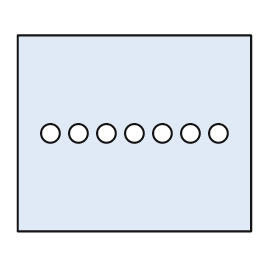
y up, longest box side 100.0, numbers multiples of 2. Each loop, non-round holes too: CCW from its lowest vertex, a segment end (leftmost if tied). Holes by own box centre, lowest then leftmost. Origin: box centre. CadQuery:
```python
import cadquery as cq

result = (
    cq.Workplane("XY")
    .moveTo(-50.0, -42.0)
    .lineTo(50.0, -42.0)
    .lineTo(50.0, 42.0)
    .lineTo(-50.0, 42.0)
    .close()
    .moveTo(-36.0, 0.0)
    .circle(4.0)
    .moveTo(-24.0, 0.0)
    .circle(4.0)
    .moveTo(-12.0, 0.0)
    .circle(4.0)
    .moveTo(0.0, 0.0)
    .circle(4.0)
    .moveTo(12.0, 0.0)
    .circle(4.0)
    .moveTo(24.0, 0.0)
    .circle(4.0)
    .moveTo(36.0, 0.0)
    .circle(4.0)
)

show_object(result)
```